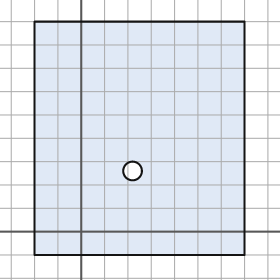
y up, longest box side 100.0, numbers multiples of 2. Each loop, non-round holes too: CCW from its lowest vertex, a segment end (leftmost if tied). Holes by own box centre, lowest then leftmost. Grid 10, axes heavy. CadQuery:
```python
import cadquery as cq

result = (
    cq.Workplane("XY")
    .moveTo(-20.0, -10.0)
    .lineTo(70.0, -10.0)
    .lineTo(70.0, 90.0)
    .lineTo(-20.0, 90.0)
    .close()
    .moveTo(22.0, 26.0)
    .circle(4.0)
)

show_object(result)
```